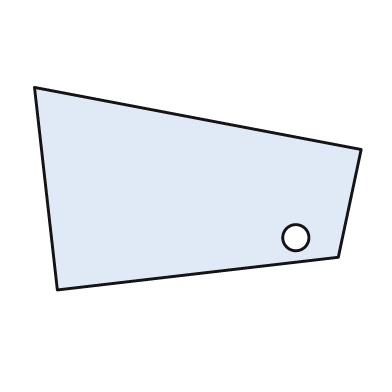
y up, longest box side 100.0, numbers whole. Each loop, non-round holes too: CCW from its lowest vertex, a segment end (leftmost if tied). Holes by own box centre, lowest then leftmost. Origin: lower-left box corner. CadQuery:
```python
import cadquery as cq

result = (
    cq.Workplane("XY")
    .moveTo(7.0, 0.0)
    .lineTo(93.0, 10.0)
    .lineTo(100.0, 43.0)
    .lineTo(0.0, 62.0)
    .close()
    .moveTo(80.0, 16.0)
    .circle(4.0)
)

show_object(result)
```